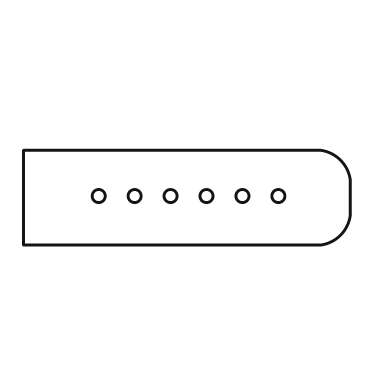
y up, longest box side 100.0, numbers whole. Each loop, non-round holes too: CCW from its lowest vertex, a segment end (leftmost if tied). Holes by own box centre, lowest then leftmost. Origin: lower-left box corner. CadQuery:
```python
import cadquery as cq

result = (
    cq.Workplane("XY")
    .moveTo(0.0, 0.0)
    .lineTo(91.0, 0.0)
    .threePointArc((97.0, 3.0), (100.0, 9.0))
    .lineTo(100.0, 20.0)
    .threePointArc((97.0, 26.0), (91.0, 29.0))
    .lineTo(0.0, 29.0)
    .close()
    .moveTo(23.0, 15.0)
    .circle(2.0)
    .moveTo(34.0, 15.0)
    .circle(2.0)
    .moveTo(45.0, 15.0)
    .circle(2.0)
    .moveTo(56.0, 15.0)
    .circle(2.0)
    .moveTo(67.0, 15.0)
    .circle(2.0)
    .moveTo(78.0, 15.0)
    .circle(2.0)
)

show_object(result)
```